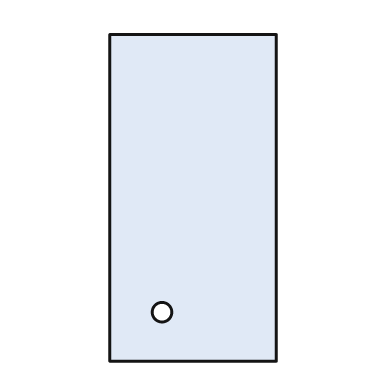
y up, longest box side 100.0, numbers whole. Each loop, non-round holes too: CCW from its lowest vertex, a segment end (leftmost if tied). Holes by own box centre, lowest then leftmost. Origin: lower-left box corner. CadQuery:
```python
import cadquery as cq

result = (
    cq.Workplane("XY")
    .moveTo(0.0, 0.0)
    .lineTo(51.0, 0.0)
    .lineTo(51.0, 100.0)
    .lineTo(0.0, 100.0)
    .close()
    .moveTo(16.0, 15.0)
    .circle(3.0)
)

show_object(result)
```